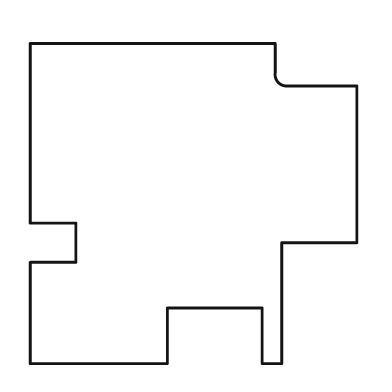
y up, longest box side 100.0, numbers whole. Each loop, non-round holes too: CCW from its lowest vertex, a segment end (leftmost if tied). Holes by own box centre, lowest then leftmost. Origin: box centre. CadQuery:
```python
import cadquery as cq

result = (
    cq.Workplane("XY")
    .moveTo(-50.0, -49.0)
    .lineTo(-8.0, -49.0)
    .lineTo(-8.0, -32.0)
    .lineTo(21.0, -32.0)
    .lineTo(21.0, -49.0)
    .lineTo(27.0, -49.0)
    .lineTo(27.0, -12.0)
    .lineTo(50.0, -12.0)
    .lineTo(50.0, 36.0)
    .lineTo(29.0, 36.0)
    .threePointArc((26.0, 37.0), (25.0, 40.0))
    .lineTo(25.0, 49.0)
    .lineTo(-50.0, 49.0)
    .lineTo(-50.0, -6.0)
    .lineTo(-36.0, -6.0)
    .lineTo(-36.0, -18.0)
    .lineTo(-50.0, -18.0)
    .close()
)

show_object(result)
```